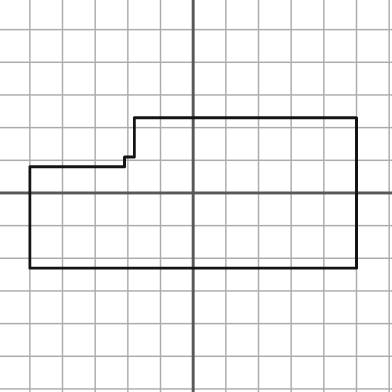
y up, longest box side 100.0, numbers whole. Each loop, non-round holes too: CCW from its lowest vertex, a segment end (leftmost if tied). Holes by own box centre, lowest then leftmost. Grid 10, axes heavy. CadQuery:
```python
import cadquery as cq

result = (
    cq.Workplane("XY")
    .moveTo(-50.0, -23.0)
    .lineTo(50.0, -23.0)
    .lineTo(50.0, 23.0)
    .lineTo(-18.0, 23.0)
    .lineTo(-18.0, 11.0)
    .lineTo(-21.0, 11.0)
    .lineTo(-21.0, 8.0)
    .lineTo(-50.0, 8.0)
    .close()
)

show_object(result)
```